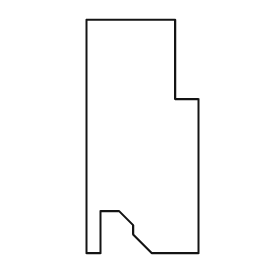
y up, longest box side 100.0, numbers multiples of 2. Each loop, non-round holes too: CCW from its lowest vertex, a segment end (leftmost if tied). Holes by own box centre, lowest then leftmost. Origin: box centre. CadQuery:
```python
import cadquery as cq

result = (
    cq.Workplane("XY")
    .moveTo(-24.0, -50.0)
    .lineTo(-18.0, -50.0)
    .lineTo(-18.0, -32.0)
    .lineTo(-10.0, -32.0)
    .lineTo(-4.0, -38.0)
    .lineTo(-4.0, -42.0)
    .lineTo(4.0, -50.0)
    .lineTo(24.0, -50.0)
    .lineTo(24.0, 16.0)
    .lineTo(14.0, 16.0)
    .lineTo(14.0, 50.0)
    .lineTo(-24.0, 50.0)
    .close()
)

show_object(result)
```